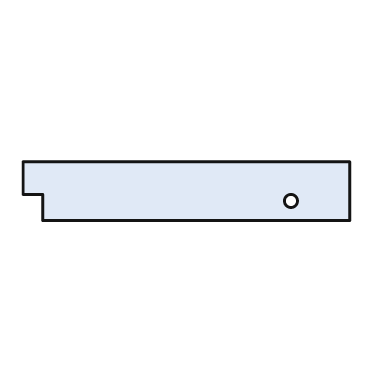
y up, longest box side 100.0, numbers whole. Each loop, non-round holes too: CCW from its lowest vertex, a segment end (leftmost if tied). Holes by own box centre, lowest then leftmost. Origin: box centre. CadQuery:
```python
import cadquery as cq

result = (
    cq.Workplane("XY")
    .moveTo(-44.0, -9.0)
    .lineTo(50.0, -9.0)
    .lineTo(50.0, 9.0)
    .lineTo(-50.0, 9.0)
    .lineTo(-50.0, -1.0)
    .lineTo(-44.0, -1.0)
    .close()
    .moveTo(32.0, -3.0)
    .circle(2.0)
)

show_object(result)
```